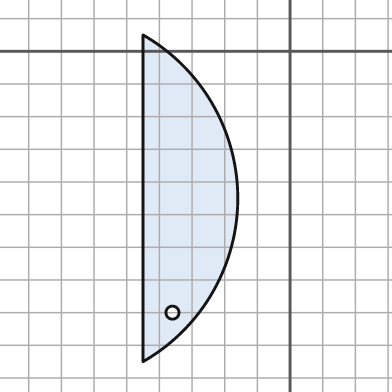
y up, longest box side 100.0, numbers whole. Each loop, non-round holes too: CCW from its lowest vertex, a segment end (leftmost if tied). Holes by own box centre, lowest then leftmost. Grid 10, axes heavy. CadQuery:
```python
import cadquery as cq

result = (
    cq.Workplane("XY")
    .moveTo(-45.0, -95.0)
    .threePointArc((-16.0, -45.0), (-45.0, 5.0))
    .close()
    .moveTo(-36.0, -80.0)
    .circle(2.0)
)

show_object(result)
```